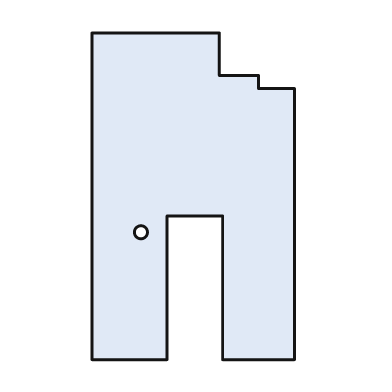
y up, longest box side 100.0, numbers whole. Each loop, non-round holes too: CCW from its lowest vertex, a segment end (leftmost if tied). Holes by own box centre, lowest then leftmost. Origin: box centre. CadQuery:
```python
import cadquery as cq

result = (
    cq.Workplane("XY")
    .moveTo(-31.0, -50.0)
    .lineTo(-8.0, -50.0)
    .lineTo(-8.0, -6.0)
    .lineTo(9.0, -6.0)
    .lineTo(9.0, -50.0)
    .lineTo(31.0, -50.0)
    .lineTo(31.0, 33.0)
    .lineTo(20.0, 33.0)
    .lineTo(20.0, 37.0)
    .lineTo(8.0, 37.0)
    .lineTo(8.0, 50.0)
    .lineTo(-31.0, 50.0)
    .close()
    .moveTo(-16.0, -11.0)
    .circle(2.0)
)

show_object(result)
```